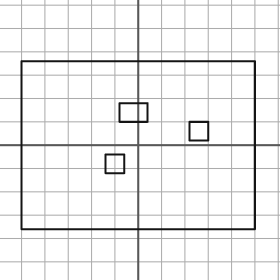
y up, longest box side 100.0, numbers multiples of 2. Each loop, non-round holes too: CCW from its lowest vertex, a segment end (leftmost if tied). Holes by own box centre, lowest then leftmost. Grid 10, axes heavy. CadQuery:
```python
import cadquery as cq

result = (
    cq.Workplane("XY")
    .moveTo(-50.0, -36.0)
    .lineTo(50.0, -36.0)
    .lineTo(50.0, 36.0)
    .lineTo(-50.0, 36.0)
    .close()
    .moveTo(-14.0, -12.0)
    .lineTo(-6.0, -12.0)
    .lineTo(-6.0, -4.0)
    .lineTo(-14.0, -4.0)
    .close()
    .moveTo(22.0, 2.0)
    .lineTo(30.0, 2.0)
    .lineTo(30.0, 10.0)
    .lineTo(22.0, 10.0)
    .close()
    .moveTo(-8.0, 10.0)
    .lineTo(4.0, 10.0)
    .lineTo(4.0, 18.0)
    .lineTo(-8.0, 18.0)
    .close()
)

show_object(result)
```